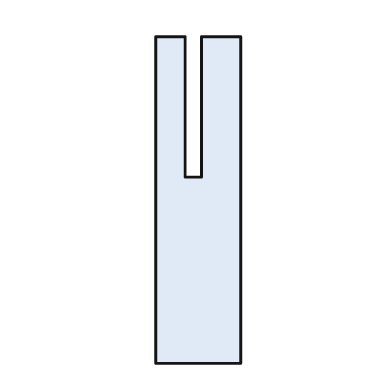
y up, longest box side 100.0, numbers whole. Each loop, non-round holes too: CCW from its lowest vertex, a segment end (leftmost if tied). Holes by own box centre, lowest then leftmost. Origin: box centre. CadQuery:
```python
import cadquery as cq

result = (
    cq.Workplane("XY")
    .moveTo(-13.0, -50.0)
    .lineTo(13.0, -50.0)
    .lineTo(13.0, 50.0)
    .lineTo(1.0, 50.0)
    .lineTo(1.0, 7.0)
    .lineTo(-4.0, 7.0)
    .lineTo(-4.0, 50.0)
    .lineTo(-13.0, 50.0)
    .close()
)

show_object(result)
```